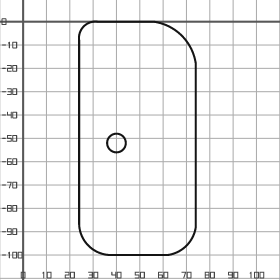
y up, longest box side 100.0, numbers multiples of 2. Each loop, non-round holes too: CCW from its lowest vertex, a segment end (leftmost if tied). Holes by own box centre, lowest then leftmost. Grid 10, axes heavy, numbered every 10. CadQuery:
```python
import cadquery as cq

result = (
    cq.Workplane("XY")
    .moveTo(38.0, -100.0)
    .lineTo(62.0, -100.0)
    .threePointArc((70.0, -96.0), (74.0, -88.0))
    .lineTo(74.0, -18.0)
    .threePointArc((68.0, -6.0), (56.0, 0.0))
    .lineTo(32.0, 0.0)
    .threePointArc((26.0, -2.0), (24.0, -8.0))
    .lineTo(24.0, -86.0)
    .threePointArc((28.0, -96.0), (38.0, -100.0))
    .close()
    .moveTo(40.0, -52.0)
    .circle(4.0)
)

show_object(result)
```